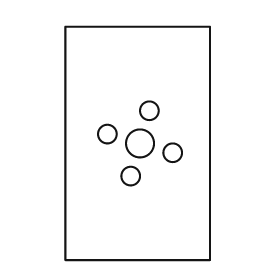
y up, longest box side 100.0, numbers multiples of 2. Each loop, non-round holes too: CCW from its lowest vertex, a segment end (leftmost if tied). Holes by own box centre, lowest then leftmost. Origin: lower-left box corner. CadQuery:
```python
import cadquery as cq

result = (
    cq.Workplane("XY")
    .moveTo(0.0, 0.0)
    .lineTo(62.0, 0.0)
    .lineTo(62.0, 100.0)
    .lineTo(0.0, 100.0)
    .close()
    .moveTo(28.0, 36.0)
    .circle(4.0)
    .moveTo(46.0, 46.0)
    .circle(4.0)
    .moveTo(32.0, 50.0)
    .circle(6.0)
    .moveTo(18.0, 54.0)
    .circle(4.0)
    .moveTo(36.0, 64.0)
    .circle(4.0)
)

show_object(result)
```